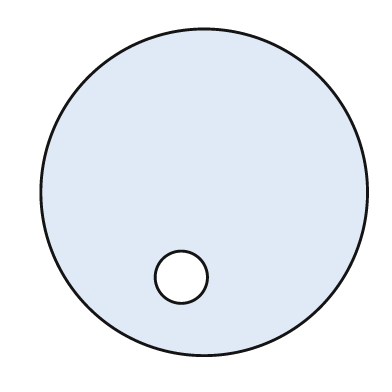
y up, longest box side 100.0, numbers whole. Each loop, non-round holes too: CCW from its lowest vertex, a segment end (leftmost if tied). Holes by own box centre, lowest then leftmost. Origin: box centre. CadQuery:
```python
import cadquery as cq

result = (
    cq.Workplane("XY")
    .moveTo(0.0, 0.0)
    .circle(50.0)
    .moveTo(-7.0, -26.0)
    .circle(8.0)
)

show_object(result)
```